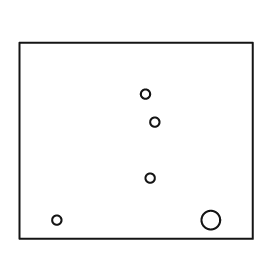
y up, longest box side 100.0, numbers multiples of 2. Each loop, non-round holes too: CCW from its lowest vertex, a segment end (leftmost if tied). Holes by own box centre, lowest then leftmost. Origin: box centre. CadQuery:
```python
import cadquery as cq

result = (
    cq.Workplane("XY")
    .moveTo(-50.0, -42.0)
    .lineTo(50.0, -42.0)
    .lineTo(50.0, 42.0)
    .lineTo(-50.0, 42.0)
    .close()
    .moveTo(-34.0, -34.0)
    .circle(2.0)
    .moveTo(32.0, -34.0)
    .circle(4.0)
    .moveTo(6.0, -16.0)
    .circle(2.0)
    .moveTo(8.0, 8.0)
    .circle(2.0)
    .moveTo(4.0, 20.0)
    .circle(2.0)
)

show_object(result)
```